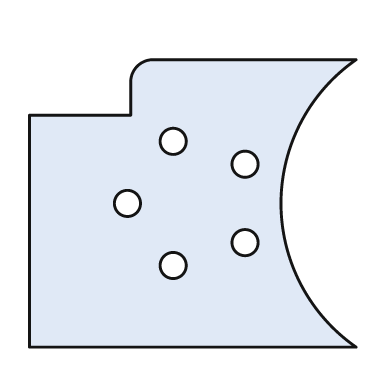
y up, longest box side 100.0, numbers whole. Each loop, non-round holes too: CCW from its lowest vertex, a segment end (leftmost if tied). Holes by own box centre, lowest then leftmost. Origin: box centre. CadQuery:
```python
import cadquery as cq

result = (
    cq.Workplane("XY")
    .moveTo(-50.0, -44.0)
    .lineTo(50.0, -44.0)
    .threePointArc((27.0, 0.0), (50.0, 44.0))
    .lineTo(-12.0, 44.0)
    .threePointArc((-17.0, 42.0), (-19.0, 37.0))
    .lineTo(-19.0, 27.0)
    .lineTo(-50.0, 27.0)
    .close()
    .moveTo(-6.0, -19.0)
    .circle(4.0)
    .moveTo(16.0, -12.0)
    .circle(4.0)
    .moveTo(-20.0, 0.0)
    .circle(4.0)
    .moveTo(16.0, 12.0)
    .circle(4.0)
    .moveTo(-6.0, 19.0)
    .circle(4.0)
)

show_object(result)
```